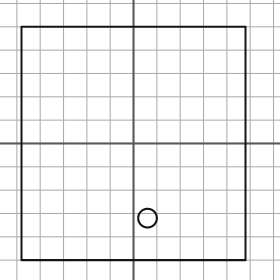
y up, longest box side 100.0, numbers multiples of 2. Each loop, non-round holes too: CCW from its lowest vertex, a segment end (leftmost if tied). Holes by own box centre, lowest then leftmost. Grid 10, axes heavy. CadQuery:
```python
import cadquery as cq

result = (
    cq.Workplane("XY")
    .moveTo(-48.0, -50.0)
    .lineTo(48.0, -50.0)
    .lineTo(48.0, 50.0)
    .lineTo(-48.0, 50.0)
    .close()
    .moveTo(6.0, -32.0)
    .circle(4.0)
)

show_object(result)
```